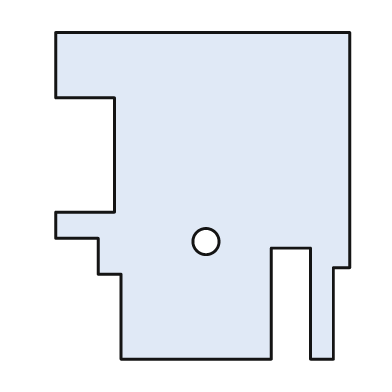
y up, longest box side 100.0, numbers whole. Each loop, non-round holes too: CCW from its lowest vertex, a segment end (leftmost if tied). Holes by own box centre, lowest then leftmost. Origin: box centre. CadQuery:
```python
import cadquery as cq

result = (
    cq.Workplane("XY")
    .moveTo(-25.0, -50.0)
    .lineTo(21.0, -50.0)
    .lineTo(21.0, -16.0)
    .lineTo(33.0, -16.0)
    .lineTo(33.0, -50.0)
    .lineTo(40.0, -50.0)
    .lineTo(40.0, -22.0)
    .lineTo(45.0, -22.0)
    .lineTo(45.0, 50.0)
    .lineTo(-45.0, 50.0)
    .lineTo(-45.0, 30.0)
    .lineTo(-27.0, 30.0)
    .lineTo(-27.0, -5.0)
    .lineTo(-45.0, -5.0)
    .lineTo(-45.0, -13.0)
    .lineTo(-32.0, -13.0)
    .lineTo(-32.0, -24.0)
    .lineTo(-25.0, -24.0)
    .close()
    .moveTo(1.0, -14.0)
    .circle(4.0)
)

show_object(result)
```